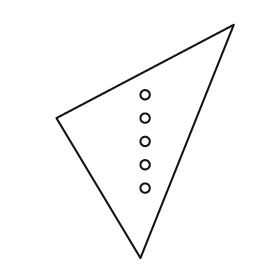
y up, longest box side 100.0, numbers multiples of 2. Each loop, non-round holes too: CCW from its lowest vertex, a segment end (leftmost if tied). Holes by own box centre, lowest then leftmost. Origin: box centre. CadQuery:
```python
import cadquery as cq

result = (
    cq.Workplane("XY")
    .moveTo(-2.0, -50.0)
    .lineTo(38.0, 50.0)
    .lineTo(-38.0, 10.0)
    .close()
    .moveTo(0.0, -20.0)
    .circle(2.0)
    .moveTo(0.0, -10.0)
    .circle(2.0)
    .moveTo(0.0, 0.0)
    .circle(2.0)
    .moveTo(0.0, 10.0)
    .circle(2.0)
    .moveTo(0.0, 20.0)
    .circle(2.0)
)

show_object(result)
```